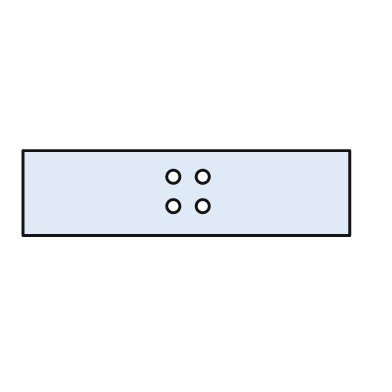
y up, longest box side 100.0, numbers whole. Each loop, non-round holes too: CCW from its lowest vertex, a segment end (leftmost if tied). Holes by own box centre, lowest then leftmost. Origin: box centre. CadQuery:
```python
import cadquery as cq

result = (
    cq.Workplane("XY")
    .moveTo(-50.0, -13.0)
    .lineTo(50.0, -13.0)
    .lineTo(50.0, 13.0)
    .lineTo(-50.0, 13.0)
    .close()
    .moveTo(-4.0, -4.0)
    .circle(2.0)
    .moveTo(5.0, -4.0)
    .circle(2.0)
    .moveTo(-4.0, 5.0)
    .circle(2.0)
    .moveTo(5.0, 5.0)
    .circle(2.0)
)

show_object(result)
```